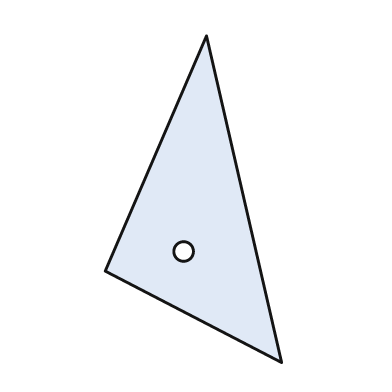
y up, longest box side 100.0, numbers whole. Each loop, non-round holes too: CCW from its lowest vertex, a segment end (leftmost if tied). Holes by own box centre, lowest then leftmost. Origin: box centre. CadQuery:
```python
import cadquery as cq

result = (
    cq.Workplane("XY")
    .moveTo(27.0, -50.0)
    .lineTo(4.0, 50.0)
    .lineTo(-27.0, -22.0)
    .close()
    .moveTo(-3.0, -16.0)
    .circle(3.0)
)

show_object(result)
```